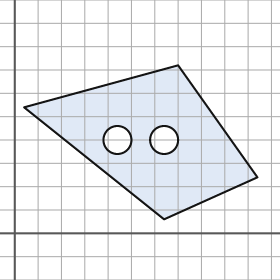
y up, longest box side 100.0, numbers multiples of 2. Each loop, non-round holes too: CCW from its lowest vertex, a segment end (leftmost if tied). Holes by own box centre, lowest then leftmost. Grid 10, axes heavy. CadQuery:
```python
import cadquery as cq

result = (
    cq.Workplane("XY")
    .moveTo(64.0, 6.0)
    .lineTo(104.0, 24.0)
    .lineTo(70.0, 72.0)
    .lineTo(4.0, 54.0)
    .close()
    .moveTo(44.0, 40.0)
    .circle(6.0)
    .moveTo(64.0, 40.0)
    .circle(6.0)
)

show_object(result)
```